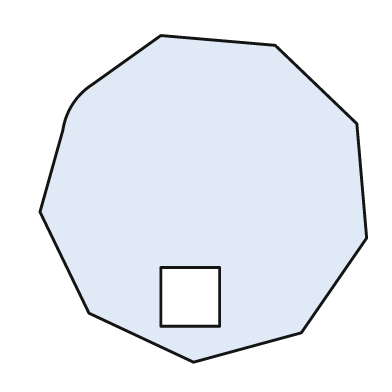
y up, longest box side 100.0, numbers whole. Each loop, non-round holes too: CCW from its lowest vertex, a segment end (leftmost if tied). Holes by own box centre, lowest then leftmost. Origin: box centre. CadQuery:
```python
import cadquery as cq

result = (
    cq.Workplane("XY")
    .moveTo(-3.0, -50.0)
    .lineTo(30.0, -41.0)
    .lineTo(50.0, -12.0)
    .lineTo(47.0, 23.0)
    .lineTo(22.0, 47.0)
    .lineTo(-13.0, 50.0)
    .lineTo(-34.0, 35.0)
    .threePointArc((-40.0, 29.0), (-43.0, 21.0))
    .lineTo(-50.0, -4.0)
    .lineTo(-35.0, -35.0)
    .close()
    .moveTo(-13.0, -39.0)
    .lineTo(5.0, -39.0)
    .lineTo(5.0, -21.0)
    .lineTo(-13.0, -21.0)
    .close()
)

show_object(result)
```